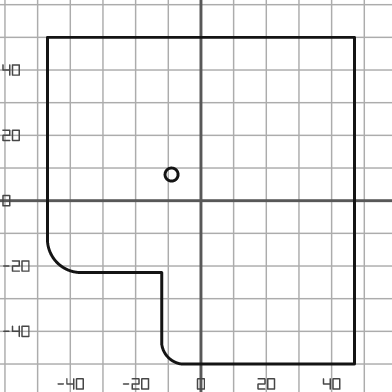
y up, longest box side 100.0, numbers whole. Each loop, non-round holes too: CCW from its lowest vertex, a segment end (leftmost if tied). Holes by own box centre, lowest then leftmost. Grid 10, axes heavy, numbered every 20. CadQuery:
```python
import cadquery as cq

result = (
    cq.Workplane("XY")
    .moveTo(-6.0, -50.0)
    .lineTo(47.0, -50.0)
    .lineTo(47.0, 50.0)
    .lineTo(-47.0, 50.0)
    .lineTo(-47.0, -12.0)
    .threePointArc((-44.0, -19.0), (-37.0, -22.0))
    .lineTo(-12.0, -22.0)
    .lineTo(-12.0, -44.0)
    .threePointArc((-10.0, -48.0), (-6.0, -50.0))
    .close()
    .moveTo(-9.0, 8.0)
    .circle(2.0)
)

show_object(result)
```